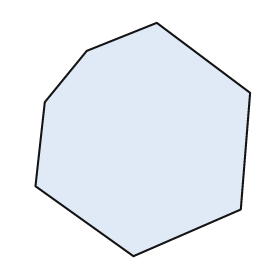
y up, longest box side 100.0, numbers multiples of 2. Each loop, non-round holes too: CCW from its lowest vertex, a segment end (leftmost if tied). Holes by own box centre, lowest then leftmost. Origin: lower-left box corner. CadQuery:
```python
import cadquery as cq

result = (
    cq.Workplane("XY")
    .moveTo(42.0, 0.0)
    .lineTo(88.0, 20.0)
    .lineTo(92.0, 70.0)
    .lineTo(52.0, 100.0)
    .lineTo(22.0, 88.0)
    .lineTo(4.0, 66.0)
    .lineTo(0.0, 30.0)
    .close()
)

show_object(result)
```